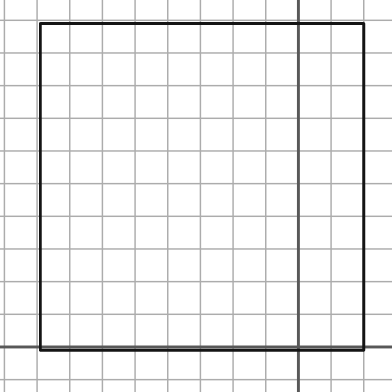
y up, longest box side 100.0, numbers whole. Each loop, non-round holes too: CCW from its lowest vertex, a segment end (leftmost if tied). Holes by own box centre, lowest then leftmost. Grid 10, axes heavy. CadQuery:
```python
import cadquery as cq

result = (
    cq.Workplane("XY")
    .moveTo(-79.0, -1.0)
    .lineTo(20.0, -1.0)
    .lineTo(20.0, 99.0)
    .lineTo(-79.0, 99.0)
    .close()
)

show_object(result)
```